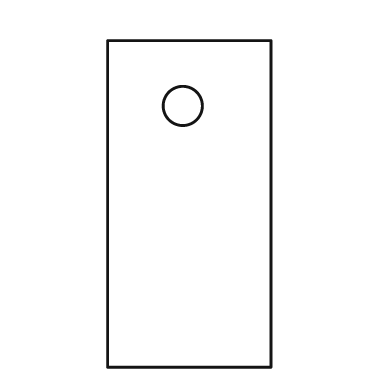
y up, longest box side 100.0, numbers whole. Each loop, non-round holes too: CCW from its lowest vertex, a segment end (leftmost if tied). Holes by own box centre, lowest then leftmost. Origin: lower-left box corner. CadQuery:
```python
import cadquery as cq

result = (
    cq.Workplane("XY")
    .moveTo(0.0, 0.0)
    .lineTo(50.0, 0.0)
    .lineTo(50.0, 100.0)
    .lineTo(0.0, 100.0)
    .close()
    .moveTo(23.0, 80.0)
    .circle(6.0)
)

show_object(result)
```